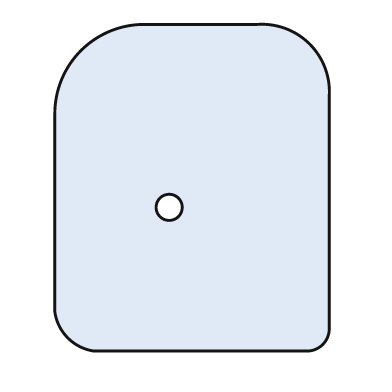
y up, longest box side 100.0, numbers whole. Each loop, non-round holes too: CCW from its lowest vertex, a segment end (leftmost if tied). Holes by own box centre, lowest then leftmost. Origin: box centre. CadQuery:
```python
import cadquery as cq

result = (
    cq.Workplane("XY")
    .moveTo(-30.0, -50.0)
    .lineTo(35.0, -50.0)
    .threePointArc((40.0, -48.0), (42.0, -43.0))
    .lineTo(42.0, 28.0)
    .threePointArc((36.0, 44.0), (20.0, 50.0))
    .lineTo(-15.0, 50.0)
    .threePointArc((-34.0, 42.0), (-42.0, 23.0))
    .lineTo(-42.0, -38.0)
    .threePointArc((-38.0, -46.0), (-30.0, -50.0))
    .close()
    .moveTo(-7.0, -6.0)
    .circle(4.0)
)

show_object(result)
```